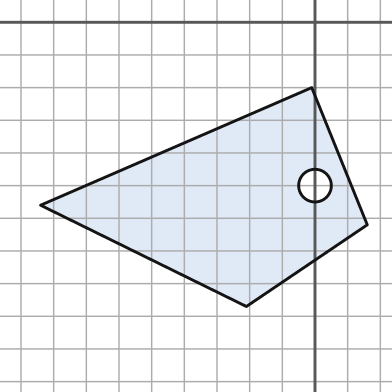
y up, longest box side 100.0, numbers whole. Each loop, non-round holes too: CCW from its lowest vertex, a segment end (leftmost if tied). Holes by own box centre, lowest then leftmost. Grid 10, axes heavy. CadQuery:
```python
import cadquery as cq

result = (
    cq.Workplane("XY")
    .moveTo(-21.0, -87.0)
    .lineTo(16.0, -62.0)
    .lineTo(-1.0, -20.0)
    .lineTo(-84.0, -56.0)
    .close()
    .moveTo(0.0, -50.0)
    .circle(5.0)
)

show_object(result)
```